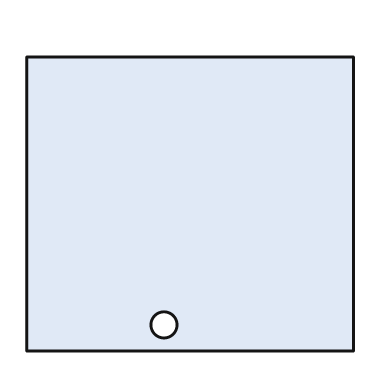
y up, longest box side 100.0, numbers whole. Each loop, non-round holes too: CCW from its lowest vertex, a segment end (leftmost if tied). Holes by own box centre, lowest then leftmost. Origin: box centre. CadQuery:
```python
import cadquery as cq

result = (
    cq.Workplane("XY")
    .moveTo(-50.0, -45.0)
    .lineTo(50.0, -45.0)
    .lineTo(50.0, 45.0)
    .lineTo(-50.0, 45.0)
    .close()
    .moveTo(-8.0, -37.0)
    .circle(4.0)
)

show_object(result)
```